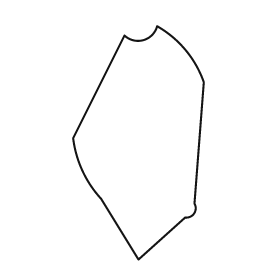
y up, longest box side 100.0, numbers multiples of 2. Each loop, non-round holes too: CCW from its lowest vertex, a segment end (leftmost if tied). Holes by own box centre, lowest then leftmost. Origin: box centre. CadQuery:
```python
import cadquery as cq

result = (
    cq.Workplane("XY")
    .moveTo(0.0, -50.0)
    .lineTo(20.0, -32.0)
    .threePointArc((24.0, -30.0), (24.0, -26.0))
    .lineTo(28.0, 26.0)
    .threePointArc((20.0, 40.0), (8.0, 50.0))
    .threePointArc((2.0, 44.0), (-6.0, 46.0))
    .lineTo(-28.0, 2.0)
    .threePointArc((-24.0, -12.0), (-16.0, -24.0))
    .close()
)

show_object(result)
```